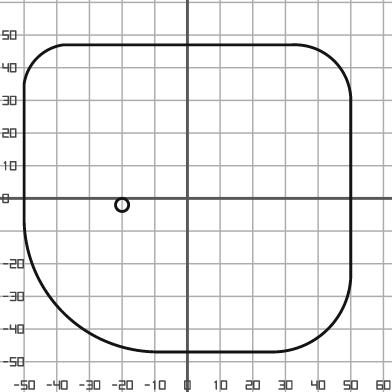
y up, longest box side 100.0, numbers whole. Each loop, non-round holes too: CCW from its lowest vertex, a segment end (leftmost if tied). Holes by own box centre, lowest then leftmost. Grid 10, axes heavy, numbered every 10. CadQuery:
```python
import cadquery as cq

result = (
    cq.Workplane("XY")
    .moveTo(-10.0, -47.0)
    .lineTo(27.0, -47.0)
    .threePointArc((43.0, -40.0), (50.0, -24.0))
    .lineTo(50.0, 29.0)
    .threePointArc((45.0, 42.0), (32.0, 47.0))
    .lineTo(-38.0, 47.0)
    .threePointArc((-46.0, 43.0), (-50.0, 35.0))
    .lineTo(-50.0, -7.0)
    .threePointArc((-38.0, -35.0), (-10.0, -47.0))
    .close()
    .moveTo(-20.0, -2.0)
    .circle(2.0)
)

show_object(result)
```